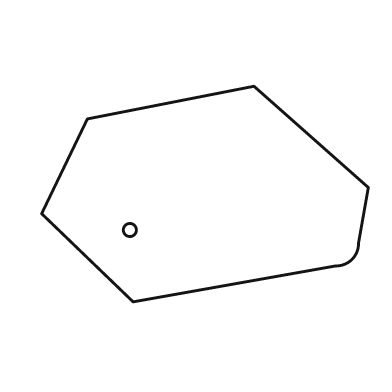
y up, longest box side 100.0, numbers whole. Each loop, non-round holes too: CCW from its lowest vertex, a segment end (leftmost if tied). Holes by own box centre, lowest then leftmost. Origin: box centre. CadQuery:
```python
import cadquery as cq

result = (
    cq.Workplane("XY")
    .moveTo(-22.0, -33.0)
    .lineTo(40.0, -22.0)
    .threePointArc((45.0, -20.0), (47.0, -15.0))
    .lineTo(50.0, 2.0)
    .lineTo(15.0, 33.0)
    .lineTo(-36.0, 23.0)
    .lineTo(-50.0, -6.0)
    .close()
    .moveTo(-23.0, -11.0)
    .circle(2.0)
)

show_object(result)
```